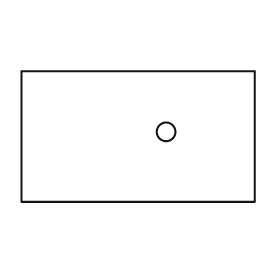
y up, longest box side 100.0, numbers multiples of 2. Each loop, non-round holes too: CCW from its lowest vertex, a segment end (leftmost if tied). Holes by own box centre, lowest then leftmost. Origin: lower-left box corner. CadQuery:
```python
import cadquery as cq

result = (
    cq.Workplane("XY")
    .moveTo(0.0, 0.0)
    .lineTo(100.0, 0.0)
    .lineTo(100.0, 56.0)
    .lineTo(0.0, 56.0)
    .close()
    .moveTo(62.0, 30.0)
    .circle(4.0)
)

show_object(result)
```